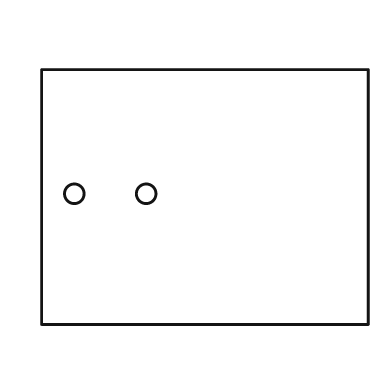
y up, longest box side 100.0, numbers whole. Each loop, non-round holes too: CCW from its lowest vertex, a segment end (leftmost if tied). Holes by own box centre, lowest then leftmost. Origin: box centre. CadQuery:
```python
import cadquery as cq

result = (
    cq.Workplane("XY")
    .moveTo(-50.0, -39.0)
    .lineTo(50.0, -39.0)
    .lineTo(50.0, 39.0)
    .lineTo(-50.0, 39.0)
    .close()
    .moveTo(-40.0, 1.0)
    .circle(3.0)
    .moveTo(-18.0, 1.0)
    .circle(3.0)
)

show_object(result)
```